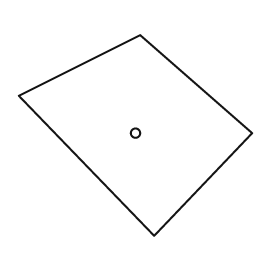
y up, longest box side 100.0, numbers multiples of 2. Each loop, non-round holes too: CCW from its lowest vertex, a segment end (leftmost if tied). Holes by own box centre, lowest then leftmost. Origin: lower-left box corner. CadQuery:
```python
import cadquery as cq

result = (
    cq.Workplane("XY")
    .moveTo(58.0, 0.0)
    .lineTo(100.0, 44.0)
    .lineTo(52.0, 86.0)
    .lineTo(0.0, 60.0)
    .close()
    .moveTo(50.0, 44.0)
    .circle(2.0)
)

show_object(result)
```